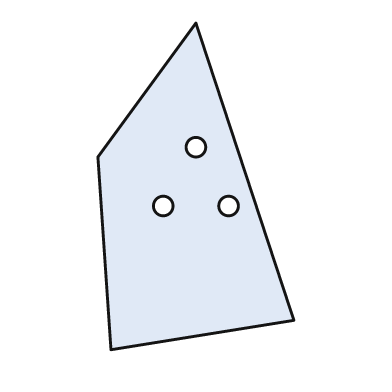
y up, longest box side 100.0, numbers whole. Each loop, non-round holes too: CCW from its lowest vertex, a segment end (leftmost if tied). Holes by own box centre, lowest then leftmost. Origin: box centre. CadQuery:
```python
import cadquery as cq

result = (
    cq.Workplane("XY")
    .moveTo(-26.0, -50.0)
    .lineTo(30.0, -41.0)
    .lineTo(0.0, 50.0)
    .lineTo(-30.0, 9.0)
    .close()
    .moveTo(-10.0, -6.0)
    .circle(3.0)
    .moveTo(10.0, -6.0)
    .circle(3.0)
    .moveTo(0.0, 12.0)
    .circle(3.0)
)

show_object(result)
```